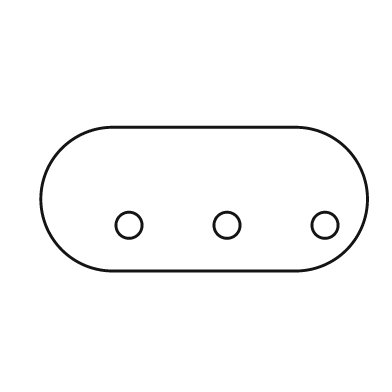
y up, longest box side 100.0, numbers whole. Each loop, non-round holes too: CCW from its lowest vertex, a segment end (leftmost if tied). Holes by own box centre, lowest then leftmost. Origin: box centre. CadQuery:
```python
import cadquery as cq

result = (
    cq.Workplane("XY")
    .moveTo(-28.0, -22.0)
    .lineTo(28.0, -22.0)
    .threePointArc((50.0, 0.0), (28.0, 22.0))
    .lineTo(-28.0, 22.0)
    .threePointArc((-50.0, 0.0), (-28.0, -22.0))
    .close()
    .moveTo(-23.0, -8.0)
    .circle(4.0)
    .moveTo(7.0, -8.0)
    .circle(4.0)
    .moveTo(37.0, -8.0)
    .circle(4.0)
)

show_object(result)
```